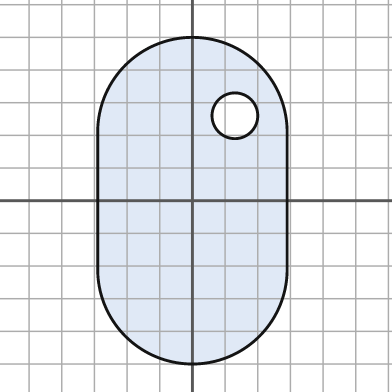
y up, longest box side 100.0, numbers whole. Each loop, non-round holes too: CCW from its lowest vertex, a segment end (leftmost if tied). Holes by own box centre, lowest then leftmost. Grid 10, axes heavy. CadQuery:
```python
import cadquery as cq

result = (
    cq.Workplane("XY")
    .moveTo(-29.0, -21.0)
    .threePointArc((0.0, -50.0), (29.0, -21.0))
    .lineTo(29.0, 21.0)
    .threePointArc((0.0, 50.0), (-29.0, 21.0))
    .close()
    .moveTo(13.0, 26.0)
    .circle(7.0)
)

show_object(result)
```